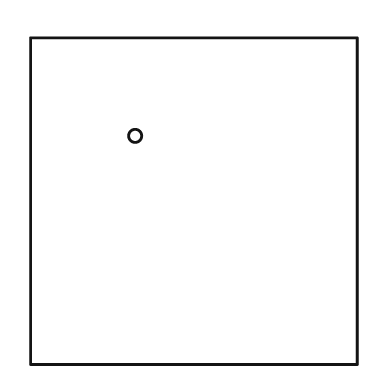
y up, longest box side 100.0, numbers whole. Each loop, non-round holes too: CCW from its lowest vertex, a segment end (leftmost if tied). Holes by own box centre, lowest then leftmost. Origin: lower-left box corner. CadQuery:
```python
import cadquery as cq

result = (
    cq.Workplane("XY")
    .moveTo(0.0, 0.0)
    .lineTo(100.0, 0.0)
    .lineTo(100.0, 100.0)
    .lineTo(0.0, 100.0)
    .close()
    .moveTo(32.0, 70.0)
    .circle(2.0)
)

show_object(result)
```